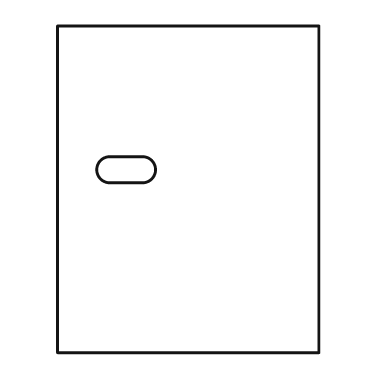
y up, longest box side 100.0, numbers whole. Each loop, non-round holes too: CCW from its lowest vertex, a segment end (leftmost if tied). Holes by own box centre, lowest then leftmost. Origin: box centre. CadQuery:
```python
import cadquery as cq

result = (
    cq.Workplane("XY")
    .moveTo(-40.0, -50.0)
    .lineTo(40.0, -50.0)
    .lineTo(40.0, 50.0)
    .lineTo(-40.0, 50.0)
    .close()
    .moveTo(-24.0, 2.0)
    .lineTo(-14.0, 2.0)
    .threePointArc((-10.0, 6.0), (-14.0, 10.0))
    .lineTo(-24.0, 10.0)
    .threePointArc((-28.0, 6.0), (-24.0, 2.0))
    .close()
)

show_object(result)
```